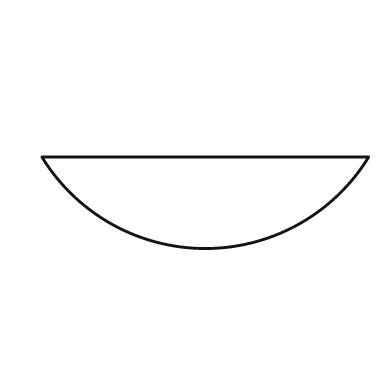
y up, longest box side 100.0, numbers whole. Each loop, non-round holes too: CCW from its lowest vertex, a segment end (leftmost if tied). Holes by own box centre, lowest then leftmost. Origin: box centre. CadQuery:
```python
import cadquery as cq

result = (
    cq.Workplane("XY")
    .moveTo(-50.0, 14.0)
    .threePointArc((0.0, -14.0), (50.0, 14.0))
    .close()
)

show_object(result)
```